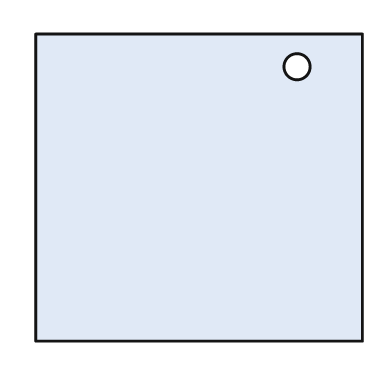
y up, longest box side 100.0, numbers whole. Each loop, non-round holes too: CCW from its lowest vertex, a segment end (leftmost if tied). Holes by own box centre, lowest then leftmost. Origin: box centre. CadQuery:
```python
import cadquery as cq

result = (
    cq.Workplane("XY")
    .moveTo(-50.0, -47.0)
    .lineTo(50.0, -47.0)
    .lineTo(50.0, 47.0)
    .lineTo(-50.0, 47.0)
    .close()
    .moveTo(30.0, 37.0)
    .circle(4.0)
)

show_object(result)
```